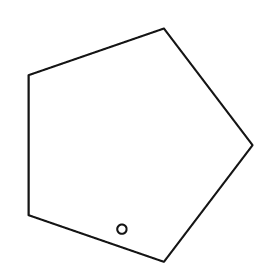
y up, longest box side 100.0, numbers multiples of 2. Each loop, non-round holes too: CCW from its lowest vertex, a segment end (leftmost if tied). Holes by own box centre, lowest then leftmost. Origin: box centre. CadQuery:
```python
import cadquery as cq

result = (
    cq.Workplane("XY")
    .moveTo(10.0, -50.0)
    .lineTo(48.0, 0.0)
    .lineTo(10.0, 50.0)
    .lineTo(-48.0, 30.0)
    .lineTo(-48.0, -30.0)
    .close()
    .moveTo(-8.0, -36.0)
    .circle(2.0)
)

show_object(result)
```